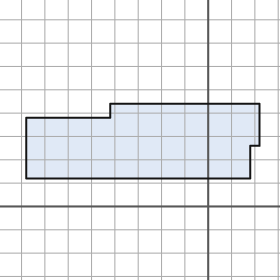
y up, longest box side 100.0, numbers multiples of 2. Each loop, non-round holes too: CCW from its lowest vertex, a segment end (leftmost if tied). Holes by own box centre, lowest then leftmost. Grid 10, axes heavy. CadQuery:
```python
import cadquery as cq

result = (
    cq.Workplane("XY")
    .moveTo(-78.0, 12.0)
    .lineTo(18.0, 12.0)
    .lineTo(18.0, 26.0)
    .lineTo(22.0, 26.0)
    .lineTo(22.0, 44.0)
    .lineTo(-42.0, 44.0)
    .lineTo(-42.0, 38.0)
    .lineTo(-78.0, 38.0)
    .close()
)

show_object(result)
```